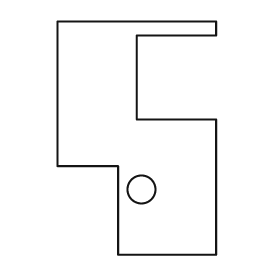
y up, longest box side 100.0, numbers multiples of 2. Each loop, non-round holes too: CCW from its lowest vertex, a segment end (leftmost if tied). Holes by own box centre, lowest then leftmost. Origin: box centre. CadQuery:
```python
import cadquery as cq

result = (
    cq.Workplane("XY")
    .moveTo(-8.0, -50.0)
    .lineTo(34.0, -50.0)
    .lineTo(34.0, 8.0)
    .lineTo(0.0, 8.0)
    .lineTo(0.0, 44.0)
    .lineTo(34.0, 44.0)
    .lineTo(34.0, 50.0)
    .lineTo(-34.0, 50.0)
    .lineTo(-34.0, -12.0)
    .lineTo(-8.0, -12.0)
    .close()
    .moveTo(2.0, -22.0)
    .circle(6.0)
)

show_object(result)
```